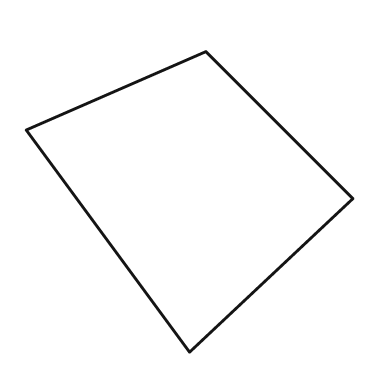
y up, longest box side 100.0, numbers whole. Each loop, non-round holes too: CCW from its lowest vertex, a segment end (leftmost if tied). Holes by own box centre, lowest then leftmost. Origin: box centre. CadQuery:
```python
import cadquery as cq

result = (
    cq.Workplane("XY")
    .moveTo(0.0, -46.0)
    .lineTo(50.0, 1.0)
    .lineTo(5.0, 46.0)
    .lineTo(-50.0, 22.0)
    .close()
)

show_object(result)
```